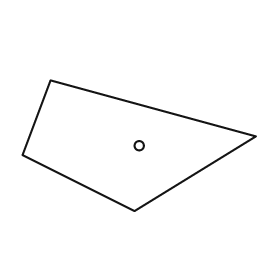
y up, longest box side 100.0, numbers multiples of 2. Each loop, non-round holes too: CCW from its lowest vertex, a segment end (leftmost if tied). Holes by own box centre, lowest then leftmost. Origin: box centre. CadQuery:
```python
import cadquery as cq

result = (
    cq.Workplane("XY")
    .moveTo(-2.0, -28.0)
    .lineTo(50.0, 4.0)
    .lineTo(-38.0, 28.0)
    .lineTo(-50.0, -4.0)
    .close()
    .moveTo(0.0, 0.0)
    .circle(2.0)
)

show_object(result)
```